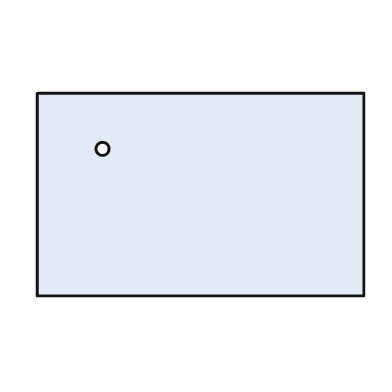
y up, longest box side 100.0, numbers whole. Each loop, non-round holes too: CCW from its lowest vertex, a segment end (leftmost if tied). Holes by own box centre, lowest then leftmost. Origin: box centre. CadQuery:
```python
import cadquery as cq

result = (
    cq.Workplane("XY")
    .moveTo(-50.0, -31.0)
    .lineTo(50.0, -31.0)
    .lineTo(50.0, 31.0)
    .lineTo(-50.0, 31.0)
    .close()
    .moveTo(-30.0, 14.0)
    .circle(2.0)
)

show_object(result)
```